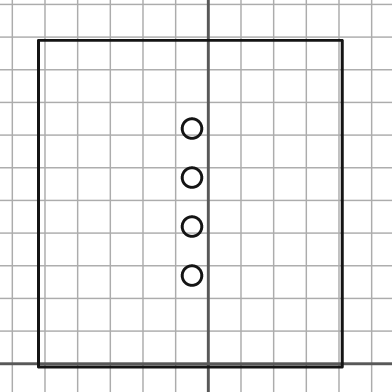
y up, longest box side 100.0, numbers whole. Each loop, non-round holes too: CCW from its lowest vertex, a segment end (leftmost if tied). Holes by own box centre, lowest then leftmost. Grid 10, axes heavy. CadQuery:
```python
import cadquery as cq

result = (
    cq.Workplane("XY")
    .moveTo(-52.0, -1.0)
    .lineTo(41.0, -1.0)
    .lineTo(41.0, 99.0)
    .lineTo(-52.0, 99.0)
    .close()
    .moveTo(-5.0, 27.0)
    .circle(3.0)
    .moveTo(-5.0, 42.0)
    .circle(3.0)
    .moveTo(-5.0, 57.0)
    .circle(3.0)
    .moveTo(-5.0, 72.0)
    .circle(3.0)
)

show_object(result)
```